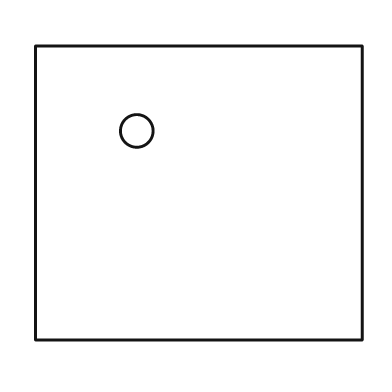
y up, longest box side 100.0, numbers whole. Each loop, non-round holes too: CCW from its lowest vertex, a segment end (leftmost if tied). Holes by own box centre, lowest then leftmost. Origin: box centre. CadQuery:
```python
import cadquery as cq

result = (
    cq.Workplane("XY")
    .moveTo(-50.0, -45.0)
    .lineTo(50.0, -45.0)
    .lineTo(50.0, 45.0)
    .lineTo(-50.0, 45.0)
    .close()
    .moveTo(-19.0, 19.0)
    .circle(5.0)
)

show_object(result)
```